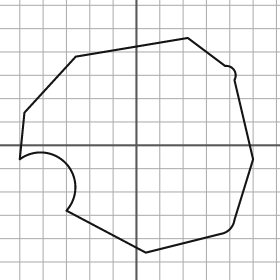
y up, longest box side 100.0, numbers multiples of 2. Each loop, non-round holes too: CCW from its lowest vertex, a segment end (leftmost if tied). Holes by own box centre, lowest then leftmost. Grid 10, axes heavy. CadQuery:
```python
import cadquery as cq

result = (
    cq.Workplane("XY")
    .moveTo(4.0, -46.0)
    .lineTo(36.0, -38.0)
    .threePointArc((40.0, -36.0), (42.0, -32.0))
    .lineTo(50.0, -6.0)
    .lineTo(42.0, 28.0)
    .threePointArc((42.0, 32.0), (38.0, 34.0))
    .lineTo(22.0, 46.0)
    .lineTo(-26.0, 38.0)
    .lineTo(-48.0, 14.0)
    .lineTo(-50.0, -6.0)
    .threePointArc((-30.0, -8.0), (-30.0, -28.0))
    .close()
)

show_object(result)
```